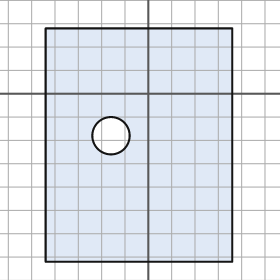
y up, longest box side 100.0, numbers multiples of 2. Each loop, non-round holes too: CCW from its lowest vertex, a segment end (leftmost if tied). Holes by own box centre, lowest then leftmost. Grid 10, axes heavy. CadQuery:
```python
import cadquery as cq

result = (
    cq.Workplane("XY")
    .moveTo(-44.0, -72.0)
    .lineTo(36.0, -72.0)
    .lineTo(36.0, 28.0)
    .lineTo(-44.0, 28.0)
    .close()
    .moveTo(-16.0, -18.0)
    .circle(8.0)
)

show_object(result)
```